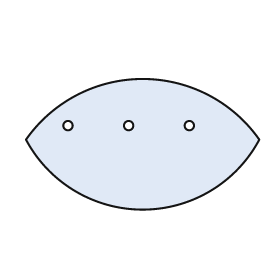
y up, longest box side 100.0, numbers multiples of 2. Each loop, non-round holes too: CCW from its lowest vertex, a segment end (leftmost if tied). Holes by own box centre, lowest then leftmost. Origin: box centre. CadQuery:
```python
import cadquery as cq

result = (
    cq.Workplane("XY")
    .moveTo(-50.0, 2.0)
    .threePointArc((0.0, -28.0), (50.0, 2.0))
    .threePointArc((0.0, 28.0), (-50.0, 2.0))
    .close()
    .moveTo(-32.0, 8.0)
    .circle(2.0)
    .moveTo(-6.0, 8.0)
    .circle(2.0)
    .moveTo(20.0, 8.0)
    .circle(2.0)
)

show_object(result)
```